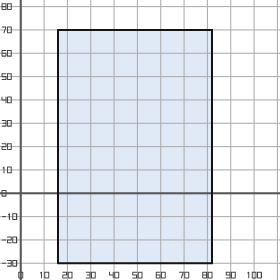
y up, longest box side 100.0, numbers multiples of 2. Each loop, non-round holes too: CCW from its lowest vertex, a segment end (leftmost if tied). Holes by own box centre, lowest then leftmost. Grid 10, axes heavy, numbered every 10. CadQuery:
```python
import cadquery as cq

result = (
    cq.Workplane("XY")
    .moveTo(16.0, -30.0)
    .lineTo(82.0, -30.0)
    .lineTo(82.0, 70.0)
    .lineTo(16.0, 70.0)
    .close()
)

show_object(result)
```